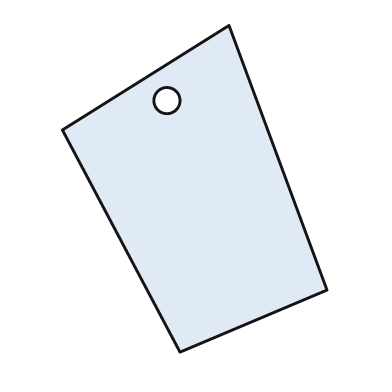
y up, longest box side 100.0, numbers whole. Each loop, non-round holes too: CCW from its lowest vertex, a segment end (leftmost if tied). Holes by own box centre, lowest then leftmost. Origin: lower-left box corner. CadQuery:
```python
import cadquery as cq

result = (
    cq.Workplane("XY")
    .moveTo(36.0, 0.0)
    .lineTo(81.0, 19.0)
    .lineTo(51.0, 100.0)
    .lineTo(0.0, 68.0)
    .close()
    .moveTo(32.0, 77.0)
    .circle(4.0)
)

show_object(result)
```